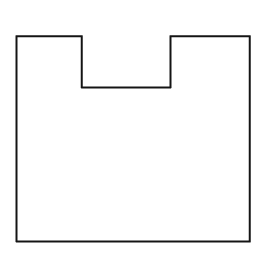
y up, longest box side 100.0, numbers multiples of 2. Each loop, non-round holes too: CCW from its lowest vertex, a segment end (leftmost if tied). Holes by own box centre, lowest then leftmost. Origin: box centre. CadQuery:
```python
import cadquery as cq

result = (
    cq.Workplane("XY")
    .moveTo(-50.0, -44.0)
    .lineTo(50.0, -44.0)
    .lineTo(50.0, 44.0)
    .lineTo(16.0, 44.0)
    .lineTo(16.0, 22.0)
    .lineTo(-22.0, 22.0)
    .lineTo(-22.0, 44.0)
    .lineTo(-50.0, 44.0)
    .close()
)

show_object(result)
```